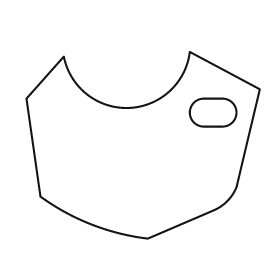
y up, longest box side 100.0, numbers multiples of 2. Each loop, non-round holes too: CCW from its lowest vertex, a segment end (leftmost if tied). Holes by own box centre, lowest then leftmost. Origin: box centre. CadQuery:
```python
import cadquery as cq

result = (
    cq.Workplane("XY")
    .moveTo(2.0, -40.0)
    .lineTo(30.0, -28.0)
    .threePointArc((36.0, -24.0), (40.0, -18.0))
    .lineTo(50.0, 24.0)
    .lineTo(20.0, 40.0)
    .threePointArc((-6.0, 16.0), (-34.0, 38.0))
    .lineTo(-50.0, 20.0)
    .lineTo(-44.0, -22.0)
    .threePointArc((-22.0, -34.0), (2.0, -40.0))
    .close()
    .moveTo(26.0, 8.0)
    .lineTo(34.0, 8.0)
    .threePointArc((40.0, 14.0), (34.0, 20.0))
    .lineTo(26.0, 20.0)
    .threePointArc((20.0, 14.0), (26.0, 8.0))
    .close()
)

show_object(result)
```